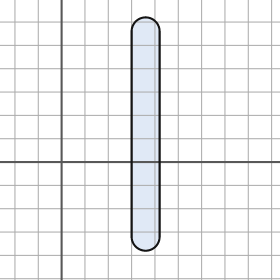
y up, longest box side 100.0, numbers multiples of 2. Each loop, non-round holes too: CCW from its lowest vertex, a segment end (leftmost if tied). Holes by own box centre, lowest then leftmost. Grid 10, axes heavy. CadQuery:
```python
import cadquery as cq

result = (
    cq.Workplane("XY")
    .moveTo(30.0, -32.0)
    .threePointArc((36.0, -38.0), (42.0, -32.0))
    .lineTo(42.0, 56.0)
    .threePointArc((36.0, 62.0), (30.0, 56.0))
    .close()
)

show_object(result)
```